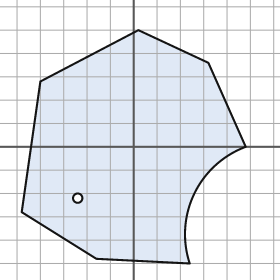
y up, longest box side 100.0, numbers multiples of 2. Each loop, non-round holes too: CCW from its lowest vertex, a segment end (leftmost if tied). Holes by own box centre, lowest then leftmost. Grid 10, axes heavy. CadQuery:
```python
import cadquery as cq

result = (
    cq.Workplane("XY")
    .moveTo(24.0, -50.0)
    .threePointArc((26.0, -20.0), (48.0, 0.0))
    .lineTo(32.0, 36.0)
    .lineTo(2.0, 50.0)
    .lineTo(-40.0, 28.0)
    .lineTo(-48.0, -28.0)
    .lineTo(-16.0, -48.0)
    .close()
    .moveTo(-24.0, -22.0)
    .circle(2.0)
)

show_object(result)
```